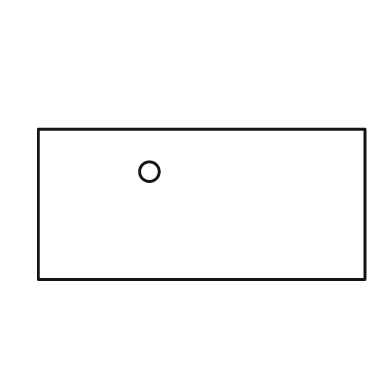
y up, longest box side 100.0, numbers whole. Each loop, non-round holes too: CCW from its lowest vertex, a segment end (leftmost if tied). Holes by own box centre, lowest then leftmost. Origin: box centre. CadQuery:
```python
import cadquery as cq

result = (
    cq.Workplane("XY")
    .moveTo(-50.0, -23.0)
    .lineTo(50.0, -23.0)
    .lineTo(50.0, 23.0)
    .lineTo(-50.0, 23.0)
    .close()
    .moveTo(-16.0, 10.0)
    .circle(3.0)
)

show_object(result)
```